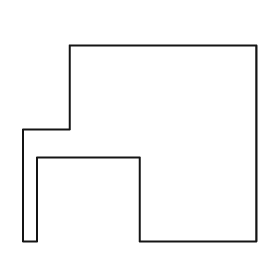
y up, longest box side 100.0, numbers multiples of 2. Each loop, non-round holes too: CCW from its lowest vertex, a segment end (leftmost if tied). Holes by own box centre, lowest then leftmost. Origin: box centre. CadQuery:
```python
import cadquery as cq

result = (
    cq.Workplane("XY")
    .moveTo(-50.0, -42.0)
    .lineTo(-44.0, -42.0)
    .lineTo(-44.0, -6.0)
    .lineTo(0.0, -6.0)
    .lineTo(0.0, -42.0)
    .lineTo(50.0, -42.0)
    .lineTo(50.0, 42.0)
    .lineTo(-30.0, 42.0)
    .lineTo(-30.0, 6.0)
    .lineTo(-50.0, 6.0)
    .close()
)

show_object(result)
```